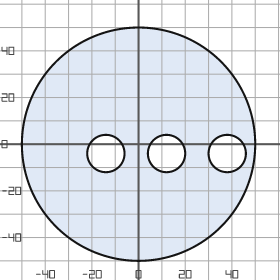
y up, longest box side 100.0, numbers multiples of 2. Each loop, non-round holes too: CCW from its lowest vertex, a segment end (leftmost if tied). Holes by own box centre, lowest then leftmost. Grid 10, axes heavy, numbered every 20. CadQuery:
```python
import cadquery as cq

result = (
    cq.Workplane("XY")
    .moveTo(0.0, 0.0)
    .circle(50.0)
    .moveTo(-14.0, -4.0)
    .circle(8.0)
    .moveTo(12.0, -4.0)
    .circle(8.0)
    .moveTo(38.0, -4.0)
    .circle(8.0)
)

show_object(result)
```